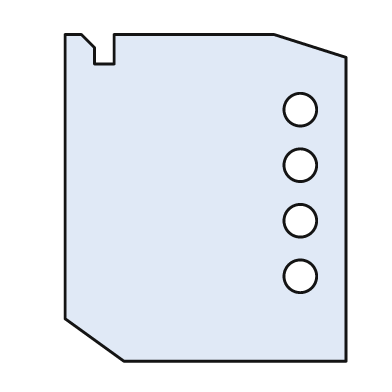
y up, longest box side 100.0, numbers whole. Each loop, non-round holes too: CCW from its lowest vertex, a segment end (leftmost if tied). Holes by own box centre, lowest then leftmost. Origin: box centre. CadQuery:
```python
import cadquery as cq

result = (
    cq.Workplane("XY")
    .moveTo(-25.0, -50.0)
    .lineTo(43.0, -50.0)
    .lineTo(43.0, 43.0)
    .lineTo(21.0, 50.0)
    .lineTo(-28.0, 50.0)
    .lineTo(-28.0, 41.0)
    .lineTo(-34.0, 41.0)
    .lineTo(-34.0, 46.0)
    .lineTo(-38.0, 50.0)
    .lineTo(-43.0, 50.0)
    .lineTo(-43.0, -37.0)
    .close()
    .moveTo(29.0, -24.0)
    .circle(5.0)
    .moveTo(29.0, -7.0)
    .circle(5.0)
    .moveTo(29.0, 10.0)
    .circle(5.0)
    .moveTo(29.0, 27.0)
    .circle(5.0)
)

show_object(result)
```